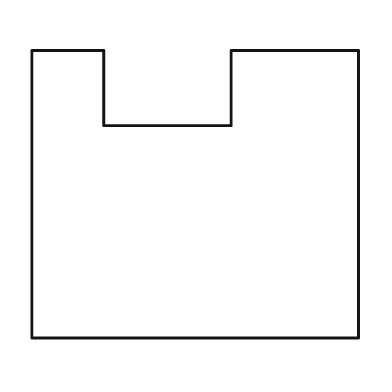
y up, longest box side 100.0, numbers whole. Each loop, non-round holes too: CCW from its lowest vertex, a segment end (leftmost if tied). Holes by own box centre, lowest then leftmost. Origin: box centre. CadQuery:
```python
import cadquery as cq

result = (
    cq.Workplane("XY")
    .moveTo(-50.0, -44.0)
    .lineTo(50.0, -44.0)
    .lineTo(50.0, 44.0)
    .lineTo(11.0, 44.0)
    .lineTo(11.0, 21.0)
    .lineTo(-28.0, 21.0)
    .lineTo(-28.0, 44.0)
    .lineTo(-50.0, 44.0)
    .close()
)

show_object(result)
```